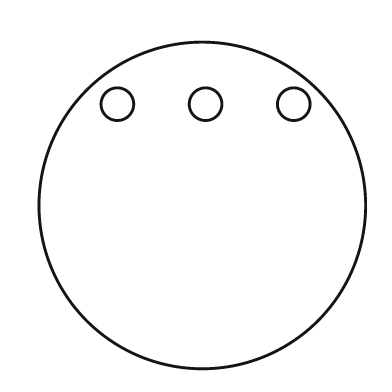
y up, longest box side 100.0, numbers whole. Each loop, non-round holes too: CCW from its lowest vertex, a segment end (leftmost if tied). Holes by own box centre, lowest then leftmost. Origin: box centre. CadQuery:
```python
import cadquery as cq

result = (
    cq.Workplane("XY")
    .moveTo(0.0, 0.0)
    .circle(50.0)
    .moveTo(-26.0, 31.0)
    .circle(5.0)
    .moveTo(1.0, 31.0)
    .circle(5.0)
    .moveTo(28.0, 31.0)
    .circle(5.0)
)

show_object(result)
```